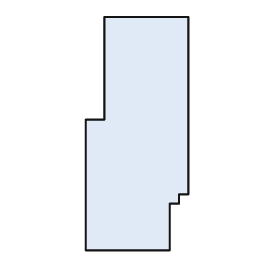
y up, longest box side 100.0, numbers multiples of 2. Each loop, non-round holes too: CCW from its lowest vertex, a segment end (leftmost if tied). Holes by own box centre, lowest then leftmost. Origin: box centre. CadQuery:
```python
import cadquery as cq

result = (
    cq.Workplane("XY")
    .moveTo(-22.0, -50.0)
    .lineTo(14.0, -50.0)
    .lineTo(14.0, -30.0)
    .lineTo(18.0, -30.0)
    .lineTo(18.0, -26.0)
    .lineTo(22.0, -26.0)
    .lineTo(22.0, 50.0)
    .lineTo(-14.0, 50.0)
    .lineTo(-14.0, 6.0)
    .lineTo(-22.0, 6.0)
    .close()
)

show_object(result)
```